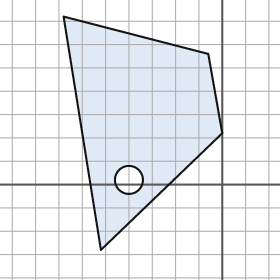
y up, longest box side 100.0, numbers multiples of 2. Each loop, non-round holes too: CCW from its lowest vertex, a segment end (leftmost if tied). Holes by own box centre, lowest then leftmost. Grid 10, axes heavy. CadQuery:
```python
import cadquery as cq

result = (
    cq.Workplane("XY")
    .moveTo(-52.0, -28.0)
    .lineTo(0.0, 22.0)
    .lineTo(-6.0, 56.0)
    .lineTo(-68.0, 72.0)
    .close()
    .moveTo(-40.0, 2.0)
    .circle(6.0)
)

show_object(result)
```